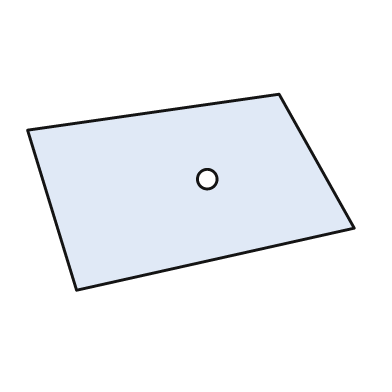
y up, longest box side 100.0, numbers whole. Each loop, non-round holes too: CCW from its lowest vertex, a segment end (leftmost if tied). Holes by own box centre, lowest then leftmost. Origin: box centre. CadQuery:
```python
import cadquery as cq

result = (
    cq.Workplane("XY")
    .moveTo(-35.0, -30.0)
    .lineTo(50.0, -11.0)
    .lineTo(27.0, 30.0)
    .lineTo(-50.0, 19.0)
    .close()
    .moveTo(5.0, 4.0)
    .circle(3.0)
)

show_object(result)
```